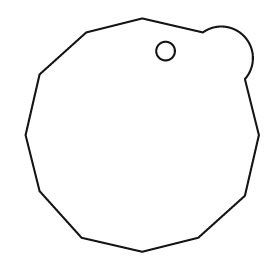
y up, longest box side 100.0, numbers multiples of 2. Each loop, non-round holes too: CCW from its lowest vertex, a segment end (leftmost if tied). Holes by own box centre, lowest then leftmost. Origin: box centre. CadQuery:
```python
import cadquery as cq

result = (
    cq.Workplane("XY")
    .moveTo(0.0, -50.0)
    .lineTo(24.0, -44.0)
    .lineTo(44.0, -26.0)
    .lineTo(50.0, 0.0)
    .lineTo(44.0, 24.0)
    .threePointArc((44.0, 42.0), (26.0, 44.0))
    .lineTo(0.0, 50.0)
    .lineTo(-24.0, 44.0)
    .lineTo(-44.0, 26.0)
    .lineTo(-50.0, 0.0)
    .lineTo(-44.0, -24.0)
    .lineTo(-26.0, -44.0)
    .close()
    .moveTo(10.0, 36.0)
    .circle(4.0)
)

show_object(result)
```